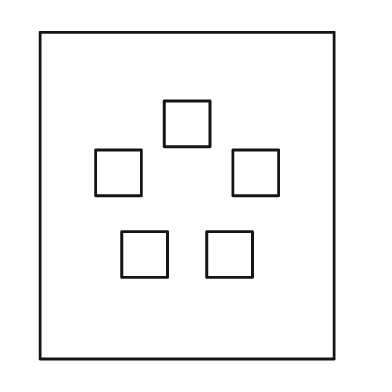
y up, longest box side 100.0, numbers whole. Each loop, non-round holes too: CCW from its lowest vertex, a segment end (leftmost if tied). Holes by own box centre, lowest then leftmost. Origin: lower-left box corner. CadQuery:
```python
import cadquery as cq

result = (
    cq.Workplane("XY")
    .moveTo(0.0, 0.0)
    .lineTo(90.0, 0.0)
    .lineTo(90.0, 100.0)
    .lineTo(0.0, 100.0)
    .close()
    .moveTo(25.0, 25.0)
    .lineTo(39.0, 25.0)
    .lineTo(39.0, 39.0)
    .lineTo(25.0, 39.0)
    .close()
    .moveTo(51.0, 25.0)
    .lineTo(65.0, 25.0)
    .lineTo(65.0, 39.0)
    .lineTo(51.0, 39.0)
    .close()
    .moveTo(17.0, 50.0)
    .lineTo(31.0, 50.0)
    .lineTo(31.0, 64.0)
    .lineTo(17.0, 64.0)
    .close()
    .moveTo(59.0, 50.0)
    .lineTo(73.0, 50.0)
    .lineTo(73.0, 64.0)
    .lineTo(59.0, 64.0)
    .close()
    .moveTo(38.0, 65.0)
    .lineTo(52.0, 65.0)
    .lineTo(52.0, 79.0)
    .lineTo(38.0, 79.0)
    .close()
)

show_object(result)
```